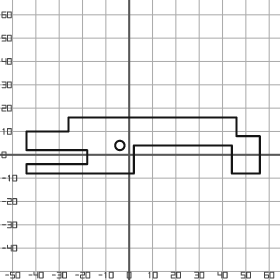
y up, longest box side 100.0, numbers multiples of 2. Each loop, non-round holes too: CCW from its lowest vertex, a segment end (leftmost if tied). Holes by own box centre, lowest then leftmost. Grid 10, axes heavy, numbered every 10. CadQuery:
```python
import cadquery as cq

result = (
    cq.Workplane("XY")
    .moveTo(-44.0, -8.0)
    .lineTo(2.0, -8.0)
    .lineTo(2.0, 4.0)
    .lineTo(44.0, 4.0)
    .lineTo(44.0, -8.0)
    .lineTo(56.0, -8.0)
    .lineTo(56.0, 8.0)
    .lineTo(46.0, 8.0)
    .lineTo(46.0, 16.0)
    .lineTo(-26.0, 16.0)
    .lineTo(-26.0, 10.0)
    .lineTo(-44.0, 10.0)
    .lineTo(-44.0, 2.0)
    .lineTo(-18.0, 2.0)
    .lineTo(-18.0, -4.0)
    .lineTo(-44.0, -4.0)
    .close()
    .moveTo(-4.0, 4.0)
    .circle(2.0)
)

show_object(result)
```